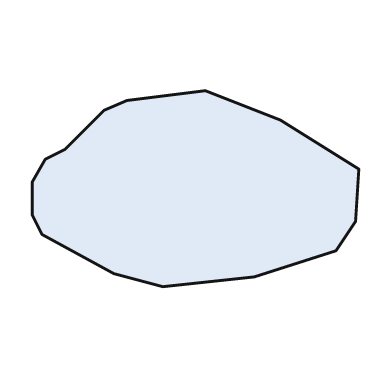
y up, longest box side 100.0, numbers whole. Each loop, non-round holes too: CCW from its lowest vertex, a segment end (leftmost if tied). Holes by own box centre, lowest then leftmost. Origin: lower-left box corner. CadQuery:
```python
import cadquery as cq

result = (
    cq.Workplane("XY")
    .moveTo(40.0, 0.0)
    .lineTo(68.0, 3.0)
    .lineTo(93.0, 11.0)
    .lineTo(99.0, 20.0)
    .lineTo(100.0, 36.0)
    .lineTo(76.0, 51.0)
    .lineTo(53.0, 60.0)
    .lineTo(29.0, 57.0)
    .lineTo(22.0, 54.0)
    .lineTo(10.0, 42.0)
    .lineTo(4.0, 39.0)
    .lineTo(0.0, 32.0)
    .lineTo(0.0, 22.0)
    .lineTo(3.0, 16.0)
    .lineTo(25.0, 4.0)
    .close()
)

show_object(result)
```